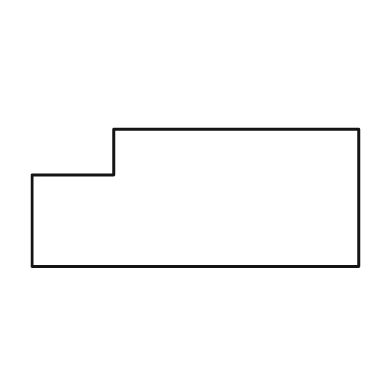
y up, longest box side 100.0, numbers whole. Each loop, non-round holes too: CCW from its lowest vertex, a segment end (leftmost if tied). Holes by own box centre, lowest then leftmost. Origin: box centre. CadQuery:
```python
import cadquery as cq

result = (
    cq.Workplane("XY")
    .moveTo(-50.0, -21.0)
    .lineTo(50.0, -21.0)
    .lineTo(50.0, 21.0)
    .lineTo(-25.0, 21.0)
    .lineTo(-25.0, 7.0)
    .lineTo(-50.0, 7.0)
    .close()
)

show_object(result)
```